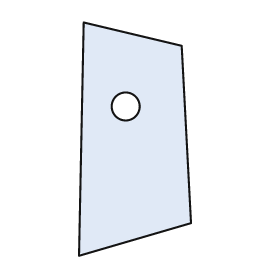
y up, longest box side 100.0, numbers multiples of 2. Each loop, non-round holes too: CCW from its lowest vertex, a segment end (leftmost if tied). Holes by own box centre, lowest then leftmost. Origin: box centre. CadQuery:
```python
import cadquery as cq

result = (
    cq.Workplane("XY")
    .moveTo(-24.0, -50.0)
    .lineTo(24.0, -36.0)
    .lineTo(20.0, 40.0)
    .lineTo(-22.0, 50.0)
    .close()
    .moveTo(-4.0, 14.0)
    .circle(6.0)
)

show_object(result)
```